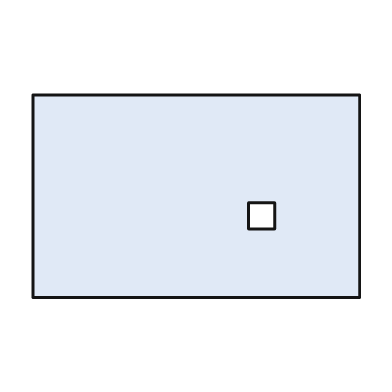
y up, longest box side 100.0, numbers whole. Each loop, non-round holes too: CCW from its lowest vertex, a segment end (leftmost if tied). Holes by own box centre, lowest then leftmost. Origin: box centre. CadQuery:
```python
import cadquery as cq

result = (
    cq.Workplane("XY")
    .moveTo(-50.0, -31.0)
    .lineTo(50.0, -31.0)
    .lineTo(50.0, 31.0)
    .lineTo(-50.0, 31.0)
    .close()
    .moveTo(16.0, -10.0)
    .lineTo(24.0, -10.0)
    .lineTo(24.0, -2.0)
    .lineTo(16.0, -2.0)
    .close()
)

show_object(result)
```